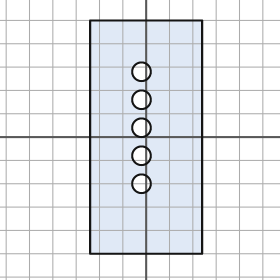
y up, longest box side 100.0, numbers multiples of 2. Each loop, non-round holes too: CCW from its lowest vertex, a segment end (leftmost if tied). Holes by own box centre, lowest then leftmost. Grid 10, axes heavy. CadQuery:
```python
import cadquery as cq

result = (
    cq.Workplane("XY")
    .moveTo(-24.0, -50.0)
    .lineTo(24.0, -50.0)
    .lineTo(24.0, 50.0)
    .lineTo(-24.0, 50.0)
    .close()
    .moveTo(-2.0, -20.0)
    .circle(4.0)
    .moveTo(-2.0, -8.0)
    .circle(4.0)
    .moveTo(-2.0, 4.0)
    .circle(4.0)
    .moveTo(-2.0, 16.0)
    .circle(4.0)
    .moveTo(-2.0, 28.0)
    .circle(4.0)
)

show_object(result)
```